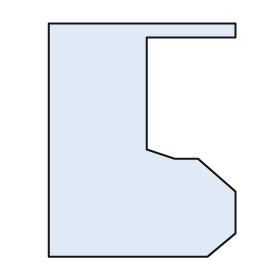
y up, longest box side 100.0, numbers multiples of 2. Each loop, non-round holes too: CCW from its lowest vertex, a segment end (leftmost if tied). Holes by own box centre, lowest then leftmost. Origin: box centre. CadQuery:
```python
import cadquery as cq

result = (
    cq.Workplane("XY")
    .moveTo(-40.0, -50.0)
    .lineTo(28.0, -50.0)
    .lineTo(40.0, -40.0)
    .lineTo(40.0, -22.0)
    .lineTo(24.0, -8.0)
    .lineTo(14.0, -8.0)
    .lineTo(2.0, -4.0)
    .lineTo(2.0, 44.0)
    .lineTo(40.0, 44.0)
    .lineTo(40.0, 50.0)
    .lineTo(-40.0, 50.0)
    .close()
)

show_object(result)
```